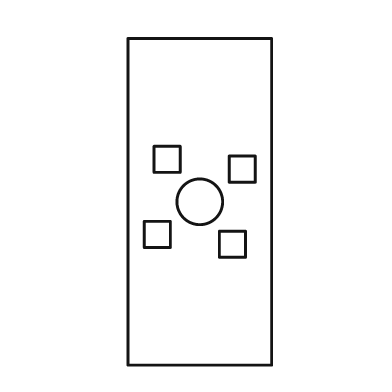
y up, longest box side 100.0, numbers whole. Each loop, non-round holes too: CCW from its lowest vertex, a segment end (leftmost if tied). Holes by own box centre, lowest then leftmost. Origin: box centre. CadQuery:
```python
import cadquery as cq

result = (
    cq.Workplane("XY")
    .moveTo(-22.0, -50.0)
    .lineTo(22.0, -50.0)
    .lineTo(22.0, 50.0)
    .lineTo(-22.0, 50.0)
    .close()
    .moveTo(6.0, -17.0)
    .lineTo(14.0, -17.0)
    .lineTo(14.0, -9.0)
    .lineTo(6.0, -9.0)
    .close()
    .moveTo(-17.0, -14.0)
    .lineTo(-9.0, -14.0)
    .lineTo(-9.0, -6.0)
    .lineTo(-17.0, -6.0)
    .close()
    .moveTo(0.0, 0.0)
    .circle(7.0)
    .moveTo(9.0, 6.0)
    .lineTo(17.0, 6.0)
    .lineTo(17.0, 14.0)
    .lineTo(9.0, 14.0)
    .close()
    .moveTo(-14.0, 9.0)
    .lineTo(-6.0, 9.0)
    .lineTo(-6.0, 17.0)
    .lineTo(-14.0, 17.0)
    .close()
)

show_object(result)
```